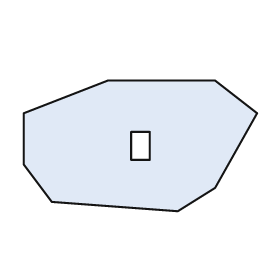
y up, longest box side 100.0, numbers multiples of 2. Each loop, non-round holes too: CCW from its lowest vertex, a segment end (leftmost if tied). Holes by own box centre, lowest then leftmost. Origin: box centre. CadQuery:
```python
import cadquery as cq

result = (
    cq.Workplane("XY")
    .moveTo(16.0, -28.0)
    .lineTo(32.0, -18.0)
    .lineTo(50.0, 14.0)
    .lineTo(32.0, 28.0)
    .lineTo(-14.0, 28.0)
    .lineTo(-50.0, 14.0)
    .lineTo(-50.0, -8.0)
    .lineTo(-38.0, -24.0)
    .close()
    .moveTo(-4.0, -6.0)
    .lineTo(4.0, -6.0)
    .lineTo(4.0, 6.0)
    .lineTo(-4.0, 6.0)
    .close()
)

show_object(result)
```